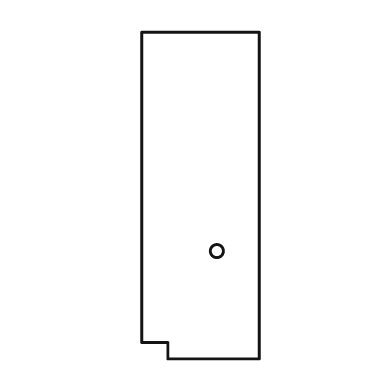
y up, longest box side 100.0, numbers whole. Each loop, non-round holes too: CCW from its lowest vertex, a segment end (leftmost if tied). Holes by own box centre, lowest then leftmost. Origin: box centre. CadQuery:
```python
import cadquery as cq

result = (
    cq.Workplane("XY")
    .moveTo(-10.0, -50.0)
    .lineTo(18.0, -50.0)
    .lineTo(18.0, 50.0)
    .lineTo(-18.0, 50.0)
    .lineTo(-18.0, -45.0)
    .lineTo(-10.0, -45.0)
    .close()
    .moveTo(5.0, -17.0)
    .circle(2.0)
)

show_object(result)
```